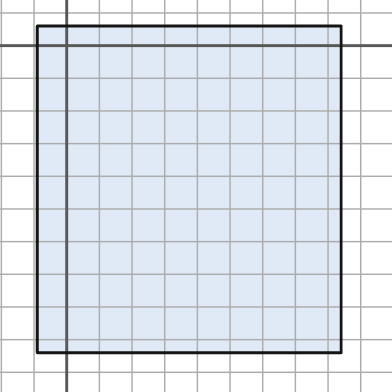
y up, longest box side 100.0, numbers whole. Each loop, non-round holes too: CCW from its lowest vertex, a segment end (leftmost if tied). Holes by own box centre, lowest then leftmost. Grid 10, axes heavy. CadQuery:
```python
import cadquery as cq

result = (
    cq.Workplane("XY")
    .moveTo(-9.0, -94.0)
    .lineTo(84.0, -94.0)
    .lineTo(84.0, 6.0)
    .lineTo(-9.0, 6.0)
    .close()
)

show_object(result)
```